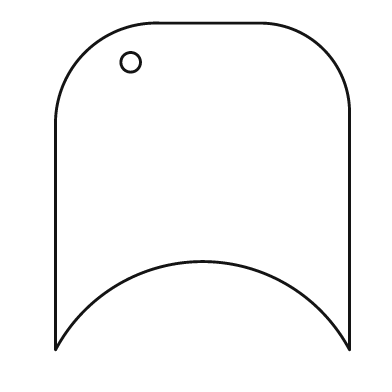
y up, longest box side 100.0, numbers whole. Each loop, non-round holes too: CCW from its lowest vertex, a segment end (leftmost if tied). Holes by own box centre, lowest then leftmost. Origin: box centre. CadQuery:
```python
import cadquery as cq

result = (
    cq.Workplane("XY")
    .moveTo(-45.0, -50.0)
    .threePointArc((0.0, -23.0), (45.0, -50.0))
    .lineTo(45.0, 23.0)
    .threePointArc((37.0, 42.0), (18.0, 50.0))
    .lineTo(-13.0, 50.0)
    .threePointArc((-36.0, 41.0), (-45.0, 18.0))
    .close()
    .moveTo(-22.0, 38.0)
    .circle(3.0)
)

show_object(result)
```